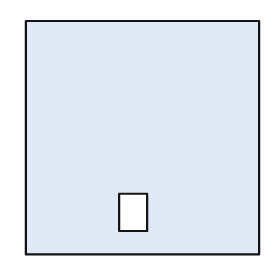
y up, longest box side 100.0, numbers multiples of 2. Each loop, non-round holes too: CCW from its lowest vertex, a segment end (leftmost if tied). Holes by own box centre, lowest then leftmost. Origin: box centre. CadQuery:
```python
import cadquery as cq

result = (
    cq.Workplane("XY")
    .moveTo(-50.0, -50.0)
    .lineTo(50.0, -50.0)
    .lineTo(50.0, 50.0)
    .lineTo(-50.0, 50.0)
    .close()
    .moveTo(-10.0, -40.0)
    .lineTo(2.0, -40.0)
    .lineTo(2.0, -24.0)
    .lineTo(-10.0, -24.0)
    .close()
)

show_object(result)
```